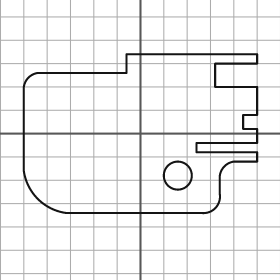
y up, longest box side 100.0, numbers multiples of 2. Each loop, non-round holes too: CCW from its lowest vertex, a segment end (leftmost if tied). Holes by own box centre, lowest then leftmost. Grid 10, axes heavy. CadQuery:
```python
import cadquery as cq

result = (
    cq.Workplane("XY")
    .moveTo(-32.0, -34.0)
    .lineTo(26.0, -34.0)
    .threePointArc((32.0, -32.0), (34.0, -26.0))
    .lineTo(34.0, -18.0)
    .threePointArc((36.0, -14.0), (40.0, -12.0))
    .lineTo(50.0, -12.0)
    .lineTo(50.0, -8.0)
    .lineTo(24.0, -8.0)
    .lineTo(24.0, -4.0)
    .lineTo(50.0, -4.0)
    .lineTo(50.0, 2.0)
    .lineTo(44.0, 2.0)
    .lineTo(44.0, 8.0)
    .lineTo(50.0, 8.0)
    .lineTo(50.0, 20.0)
    .lineTo(32.0, 20.0)
    .lineTo(32.0, 30.0)
    .lineTo(50.0, 30.0)
    .lineTo(50.0, 34.0)
    .lineTo(-6.0, 34.0)
    .lineTo(-6.0, 26.0)
    .lineTo(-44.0, 26.0)
    .threePointArc((-48.0, 24.0), (-50.0, 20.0))
    .lineTo(-50.0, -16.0)
    .threePointArc((-44.0, -28.0), (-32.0, -34.0))
    .close()
    .moveTo(16.0, -18.0)
    .circle(6.0)
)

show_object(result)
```